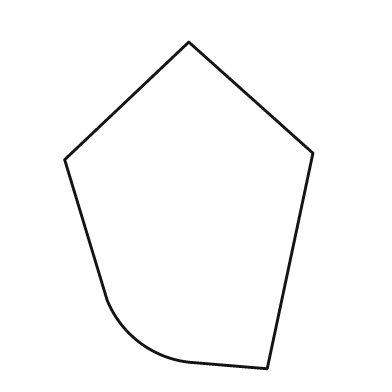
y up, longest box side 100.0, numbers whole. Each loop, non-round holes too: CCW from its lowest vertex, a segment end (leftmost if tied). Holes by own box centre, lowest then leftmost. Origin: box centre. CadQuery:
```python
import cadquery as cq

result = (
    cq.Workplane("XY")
    .moveTo(24.0, -50.0)
    .lineTo(38.0, 16.0)
    .lineTo(0.0, 50.0)
    .lineTo(-38.0, 14.0)
    .lineTo(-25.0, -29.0)
    .threePointArc((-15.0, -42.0), (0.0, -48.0))
    .close()
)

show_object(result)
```